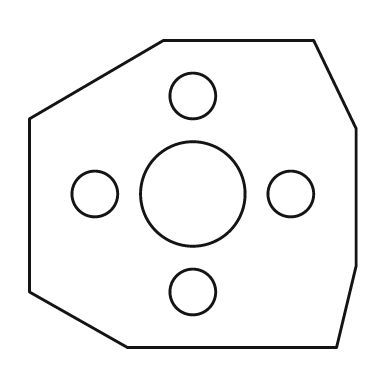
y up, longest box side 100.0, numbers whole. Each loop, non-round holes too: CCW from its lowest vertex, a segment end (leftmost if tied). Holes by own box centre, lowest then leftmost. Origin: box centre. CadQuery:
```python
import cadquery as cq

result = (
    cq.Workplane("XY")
    .moveTo(-20.0, -47.0)
    .lineTo(44.0, -47.0)
    .lineTo(50.0, -22.0)
    .lineTo(50.0, 20.0)
    .lineTo(37.0, 47.0)
    .lineTo(-9.0, 47.0)
    .lineTo(-50.0, 23.0)
    .lineTo(-50.0, -30.0)
    .close()
    .moveTo(0.0, -30.0)
    .circle(7.0)
    .moveTo(-30.0, 0.0)
    .circle(7.0)
    .moveTo(0.0, 0.0)
    .circle(16.0)
    .moveTo(30.0, 0.0)
    .circle(7.0)
    .moveTo(0.0, 30.0)
    .circle(7.0)
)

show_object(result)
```